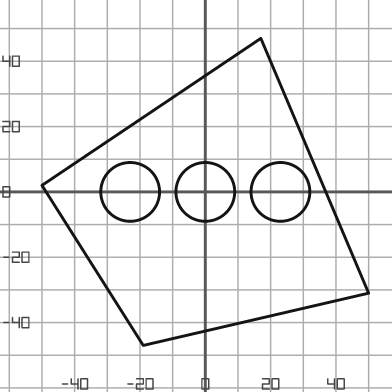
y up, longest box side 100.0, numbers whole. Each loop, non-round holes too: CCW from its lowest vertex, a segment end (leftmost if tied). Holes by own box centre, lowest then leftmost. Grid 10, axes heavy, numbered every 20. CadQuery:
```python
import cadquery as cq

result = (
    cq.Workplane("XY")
    .moveTo(-19.0, -47.0)
    .lineTo(50.0, -31.0)
    .lineTo(17.0, 47.0)
    .lineTo(-50.0, 2.0)
    .close()
    .moveTo(-23.0, 0.0)
    .circle(9.0)
    .moveTo(0.0, 0.0)
    .circle(9.0)
    .moveTo(23.0, 0.0)
    .circle(9.0)
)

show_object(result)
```